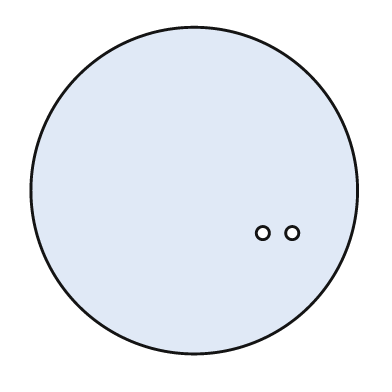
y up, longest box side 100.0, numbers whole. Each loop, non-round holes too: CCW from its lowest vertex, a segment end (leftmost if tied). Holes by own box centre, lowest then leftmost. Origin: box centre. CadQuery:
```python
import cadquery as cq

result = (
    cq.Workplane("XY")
    .moveTo(0.0, 0.0)
    .circle(50.0)
    .moveTo(21.0, -13.0)
    .circle(2.0)
    .moveTo(30.0, -13.0)
    .circle(2.0)
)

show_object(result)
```